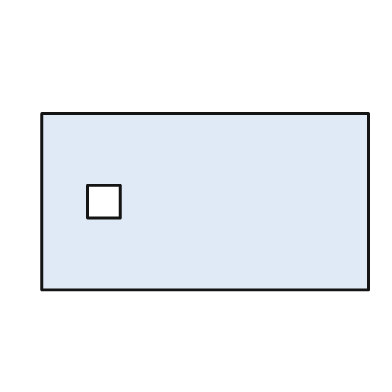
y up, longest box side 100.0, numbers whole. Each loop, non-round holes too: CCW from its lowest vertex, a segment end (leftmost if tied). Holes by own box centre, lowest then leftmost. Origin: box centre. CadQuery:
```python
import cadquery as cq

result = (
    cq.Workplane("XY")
    .moveTo(-50.0, -27.0)
    .lineTo(50.0, -27.0)
    .lineTo(50.0, 27.0)
    .lineTo(-50.0, 27.0)
    .close()
    .moveTo(-36.0, -5.0)
    .lineTo(-26.0, -5.0)
    .lineTo(-26.0, 5.0)
    .lineTo(-36.0, 5.0)
    .close()
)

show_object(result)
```